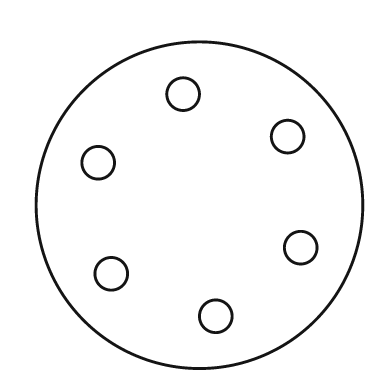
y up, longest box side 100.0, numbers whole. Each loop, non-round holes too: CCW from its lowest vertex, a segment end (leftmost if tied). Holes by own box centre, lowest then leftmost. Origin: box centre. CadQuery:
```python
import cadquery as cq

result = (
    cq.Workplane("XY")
    .moveTo(0.0, 0.0)
    .circle(50.0)
    .moveTo(5.0, -34.0)
    .circle(5.0)
    .moveTo(-27.0, -21.0)
    .circle(5.0)
    .moveTo(31.0, -13.0)
    .circle(5.0)
    .moveTo(-31.0, 13.0)
    .circle(5.0)
    .moveTo(27.0, 21.0)
    .circle(5.0)
    .moveTo(-5.0, 34.0)
    .circle(5.0)
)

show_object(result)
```